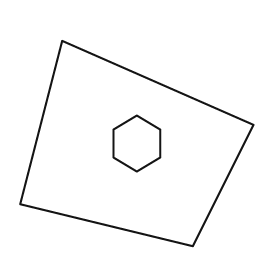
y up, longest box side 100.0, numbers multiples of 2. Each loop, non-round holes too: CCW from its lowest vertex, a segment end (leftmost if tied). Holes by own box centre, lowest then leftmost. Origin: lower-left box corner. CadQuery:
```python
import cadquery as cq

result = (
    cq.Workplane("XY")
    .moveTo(74.0, 0.0)
    .lineTo(100.0, 52.0)
    .lineTo(18.0, 88.0)
    .lineTo(0.0, 18.0)
    .close()
    .moveTo(50.0, 32.0)
    .lineTo(60.0, 38.0)
    .lineTo(60.0, 50.0)
    .lineTo(50.0, 56.0)
    .lineTo(40.0, 50.0)
    .lineTo(40.0, 38.0)
    .close()
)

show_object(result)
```